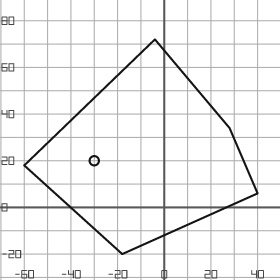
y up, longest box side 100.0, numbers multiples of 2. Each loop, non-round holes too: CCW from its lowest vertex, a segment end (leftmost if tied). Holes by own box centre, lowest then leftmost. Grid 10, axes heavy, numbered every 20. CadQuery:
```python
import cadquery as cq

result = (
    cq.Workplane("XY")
    .moveTo(-18.0, -20.0)
    .lineTo(40.0, 6.0)
    .lineTo(28.0, 34.0)
    .lineTo(-4.0, 72.0)
    .lineTo(-60.0, 18.0)
    .close()
    .moveTo(-30.0, 20.0)
    .circle(2.0)
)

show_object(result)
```